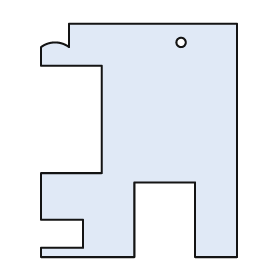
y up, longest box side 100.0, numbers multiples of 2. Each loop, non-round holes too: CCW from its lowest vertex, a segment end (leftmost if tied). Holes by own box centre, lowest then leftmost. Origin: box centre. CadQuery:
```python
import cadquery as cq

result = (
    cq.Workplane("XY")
    .moveTo(-42.0, -50.0)
    .lineTo(-2.0, -50.0)
    .lineTo(-2.0, -18.0)
    .lineTo(24.0, -18.0)
    .lineTo(24.0, -50.0)
    .lineTo(42.0, -50.0)
    .lineTo(42.0, 50.0)
    .lineTo(-30.0, 50.0)
    .lineTo(-30.0, 40.0)
    .threePointArc((-36.0, 42.0), (-42.0, 40.0))
    .lineTo(-42.0, 32.0)
    .lineTo(-16.0, 32.0)
    .lineTo(-16.0, -14.0)
    .lineTo(-42.0, -14.0)
    .lineTo(-42.0, -34.0)
    .lineTo(-24.0, -34.0)
    .lineTo(-24.0, -46.0)
    .lineTo(-42.0, -46.0)
    .close()
    .moveTo(18.0, 42.0)
    .circle(2.0)
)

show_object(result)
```